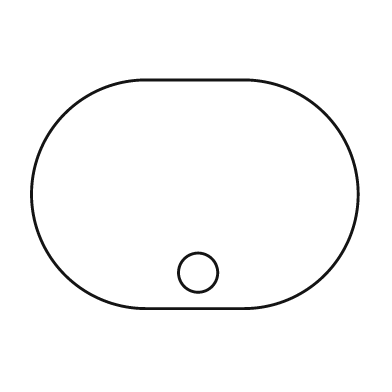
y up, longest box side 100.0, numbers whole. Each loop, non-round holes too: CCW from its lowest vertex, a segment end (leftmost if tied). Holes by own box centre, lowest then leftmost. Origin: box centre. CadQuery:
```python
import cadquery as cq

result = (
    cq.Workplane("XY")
    .moveTo(-15.0, -35.0)
    .lineTo(15.0, -35.0)
    .threePointArc((50.0, 0.0), (15.0, 35.0))
    .lineTo(-15.0, 35.0)
    .threePointArc((-50.0, 0.0), (-15.0, -35.0))
    .close()
    .moveTo(1.0, -24.0)
    .circle(6.0)
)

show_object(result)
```